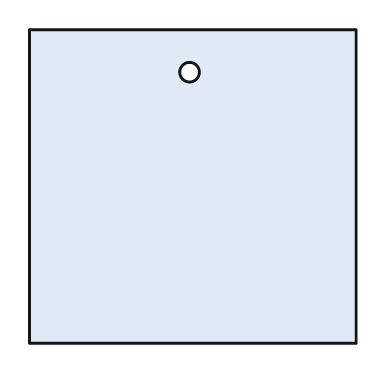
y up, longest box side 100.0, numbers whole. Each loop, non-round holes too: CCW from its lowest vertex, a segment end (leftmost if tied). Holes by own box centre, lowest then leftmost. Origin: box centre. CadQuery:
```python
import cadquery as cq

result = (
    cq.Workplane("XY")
    .moveTo(-50.0, -48.0)
    .lineTo(50.0, -48.0)
    .lineTo(50.0, 48.0)
    .lineTo(-50.0, 48.0)
    .close()
    .moveTo(-1.0, 35.0)
    .circle(3.0)
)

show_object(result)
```